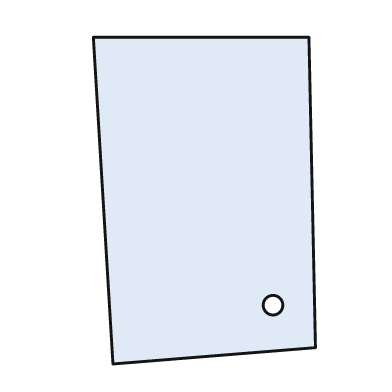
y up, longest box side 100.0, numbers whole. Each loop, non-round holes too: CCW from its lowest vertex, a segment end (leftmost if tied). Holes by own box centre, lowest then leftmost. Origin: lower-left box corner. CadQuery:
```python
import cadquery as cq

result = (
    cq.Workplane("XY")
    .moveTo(6.0, 0.0)
    .lineTo(68.0, 5.0)
    .lineTo(66.0, 100.0)
    .lineTo(0.0, 100.0)
    .close()
    .moveTo(55.0, 18.0)
    .circle(3.0)
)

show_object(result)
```